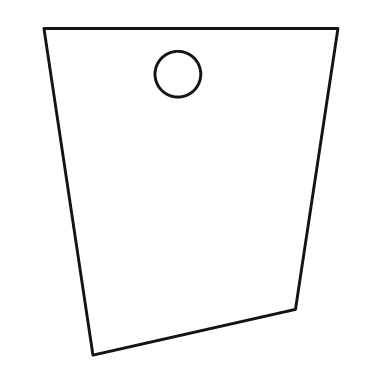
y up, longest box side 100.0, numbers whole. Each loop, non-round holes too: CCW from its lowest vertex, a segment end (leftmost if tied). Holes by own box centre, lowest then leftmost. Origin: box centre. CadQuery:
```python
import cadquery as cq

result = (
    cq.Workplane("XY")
    .moveTo(-30.0, -50.0)
    .lineTo(32.0, -36.0)
    .lineTo(45.0, 50.0)
    .lineTo(-45.0, 50.0)
    .close()
    .moveTo(-4.0, 36.0)
    .circle(7.0)
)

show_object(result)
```